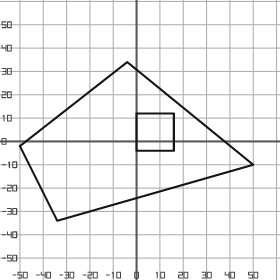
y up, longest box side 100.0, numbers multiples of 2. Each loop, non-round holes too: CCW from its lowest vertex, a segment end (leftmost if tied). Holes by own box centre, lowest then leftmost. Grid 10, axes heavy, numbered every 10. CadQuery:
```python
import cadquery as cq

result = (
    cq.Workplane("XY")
    .moveTo(-34.0, -34.0)
    .lineTo(50.0, -10.0)
    .lineTo(-4.0, 34.0)
    .lineTo(-50.0, -2.0)
    .close()
    .moveTo(0.0, -4.0)
    .lineTo(16.0, -4.0)
    .lineTo(16.0, 12.0)
    .lineTo(0.0, 12.0)
    .close()
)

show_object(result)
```